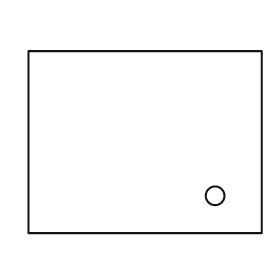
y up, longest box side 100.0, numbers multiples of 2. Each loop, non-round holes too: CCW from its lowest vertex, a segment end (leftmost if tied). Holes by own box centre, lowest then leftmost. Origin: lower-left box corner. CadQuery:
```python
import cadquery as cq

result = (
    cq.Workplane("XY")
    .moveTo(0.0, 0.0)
    .lineTo(100.0, 0.0)
    .lineTo(100.0, 78.0)
    .lineTo(0.0, 78.0)
    .close()
    .moveTo(80.0, 16.0)
    .circle(4.0)
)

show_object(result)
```